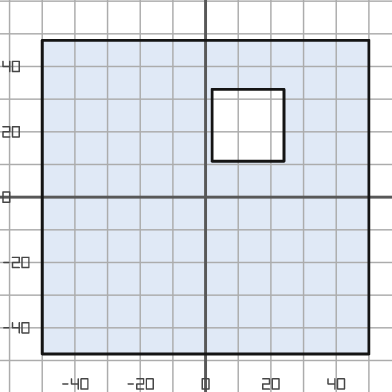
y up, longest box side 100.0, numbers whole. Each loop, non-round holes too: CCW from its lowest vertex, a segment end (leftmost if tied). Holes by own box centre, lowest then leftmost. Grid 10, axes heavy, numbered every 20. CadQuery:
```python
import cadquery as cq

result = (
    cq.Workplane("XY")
    .moveTo(-50.0, -48.0)
    .lineTo(50.0, -48.0)
    .lineTo(50.0, 48.0)
    .lineTo(-50.0, 48.0)
    .close()
    .moveTo(2.0, 11.0)
    .lineTo(24.0, 11.0)
    .lineTo(24.0, 33.0)
    .lineTo(2.0, 33.0)
    .close()
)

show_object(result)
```